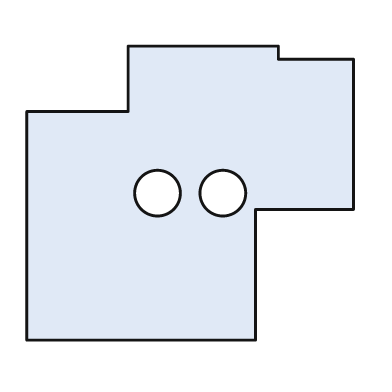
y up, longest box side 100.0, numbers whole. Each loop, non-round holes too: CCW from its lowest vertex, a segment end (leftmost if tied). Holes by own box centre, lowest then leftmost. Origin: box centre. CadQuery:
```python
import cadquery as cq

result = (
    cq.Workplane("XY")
    .moveTo(-50.0, -45.0)
    .lineTo(20.0, -45.0)
    .lineTo(20.0, -5.0)
    .lineTo(50.0, -5.0)
    .lineTo(50.0, 41.0)
    .lineTo(27.0, 41.0)
    .lineTo(27.0, 45.0)
    .lineTo(-19.0, 45.0)
    .lineTo(-19.0, 25.0)
    .lineTo(-50.0, 25.0)
    .close()
    .moveTo(-10.0, 0.0)
    .circle(7.0)
    .moveTo(10.0, 0.0)
    .circle(7.0)
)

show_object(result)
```